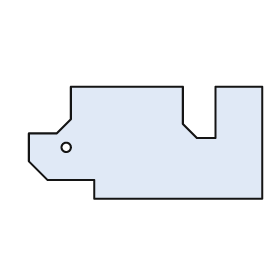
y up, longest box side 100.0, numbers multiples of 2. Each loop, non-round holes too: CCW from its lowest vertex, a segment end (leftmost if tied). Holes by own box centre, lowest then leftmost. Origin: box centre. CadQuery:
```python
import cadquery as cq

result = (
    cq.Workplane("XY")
    .moveTo(-22.0, -24.0)
    .lineTo(50.0, -24.0)
    .lineTo(50.0, 24.0)
    .lineTo(30.0, 24.0)
    .lineTo(30.0, 2.0)
    .lineTo(22.0, 2.0)
    .lineTo(16.0, 8.0)
    .lineTo(16.0, 24.0)
    .lineTo(-32.0, 24.0)
    .lineTo(-32.0, 10.0)
    .lineTo(-38.0, 4.0)
    .lineTo(-50.0, 4.0)
    .lineTo(-50.0, -8.0)
    .lineTo(-42.0, -16.0)
    .lineTo(-22.0, -16.0)
    .close()
    .moveTo(-34.0, -2.0)
    .circle(2.0)
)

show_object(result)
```